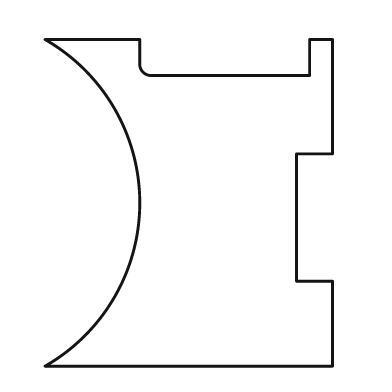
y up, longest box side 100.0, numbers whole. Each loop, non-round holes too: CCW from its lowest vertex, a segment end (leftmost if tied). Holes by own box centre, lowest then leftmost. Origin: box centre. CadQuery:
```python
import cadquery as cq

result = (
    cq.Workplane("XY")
    .moveTo(-44.0, -50.0)
    .lineTo(44.0, -50.0)
    .lineTo(44.0, -24.0)
    .lineTo(33.0, -24.0)
    .lineTo(33.0, 15.0)
    .lineTo(44.0, 15.0)
    .lineTo(44.0, 50.0)
    .lineTo(37.0, 50.0)
    .lineTo(37.0, 39.0)
    .lineTo(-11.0, 39.0)
    .threePointArc((-14.0, 40.0), (-15.0, 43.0))
    .lineTo(-15.0, 50.0)
    .lineTo(-44.0, 50.0)
    .threePointArc((-15.0, 0.0), (-44.0, -50.0))
    .close()
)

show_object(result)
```